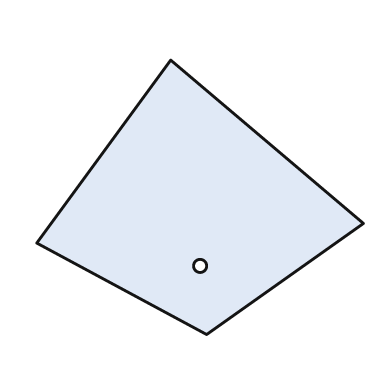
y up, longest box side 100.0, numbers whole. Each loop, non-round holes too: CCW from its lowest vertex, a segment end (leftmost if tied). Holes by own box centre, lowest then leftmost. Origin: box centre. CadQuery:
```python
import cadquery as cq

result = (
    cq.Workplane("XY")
    .moveTo(2.0, -42.0)
    .lineTo(50.0, -8.0)
    .lineTo(-9.0, 42.0)
    .lineTo(-50.0, -14.0)
    .close()
    .moveTo(0.0, -21.0)
    .circle(2.0)
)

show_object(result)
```